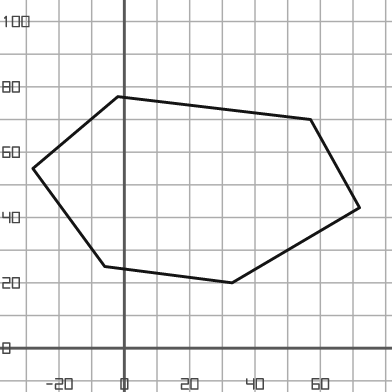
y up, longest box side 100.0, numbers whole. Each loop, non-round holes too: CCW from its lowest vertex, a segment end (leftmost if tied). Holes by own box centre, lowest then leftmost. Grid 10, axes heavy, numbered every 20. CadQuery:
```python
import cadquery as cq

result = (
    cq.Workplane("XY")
    .moveTo(33.0, 20.0)
    .lineTo(72.0, 43.0)
    .lineTo(57.0, 70.0)
    .lineTo(-2.0, 77.0)
    .lineTo(-28.0, 55.0)
    .lineTo(-6.0, 25.0)
    .close()
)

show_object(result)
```